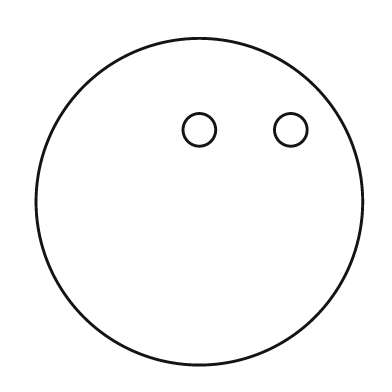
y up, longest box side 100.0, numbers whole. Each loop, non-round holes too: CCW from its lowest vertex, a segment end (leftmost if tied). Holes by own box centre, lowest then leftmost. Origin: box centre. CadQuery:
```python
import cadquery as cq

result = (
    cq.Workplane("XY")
    .moveTo(0.0, 0.0)
    .circle(50.0)
    .moveTo(0.0, 22.0)
    .circle(5.0)
    .moveTo(28.0, 22.0)
    .circle(5.0)
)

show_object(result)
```